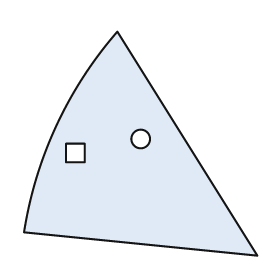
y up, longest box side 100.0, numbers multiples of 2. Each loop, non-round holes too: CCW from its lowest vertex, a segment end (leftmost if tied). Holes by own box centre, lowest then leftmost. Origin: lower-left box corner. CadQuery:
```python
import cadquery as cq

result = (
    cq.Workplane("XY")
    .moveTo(100.0, 0.0)
    .lineTo(40.0, 96.0)
    .threePointArc((14.0, 56.0), (0.0, 10.0))
    .close()
    .moveTo(18.0, 40.0)
    .lineTo(26.0, 40.0)
    .lineTo(26.0, 48.0)
    .lineTo(18.0, 48.0)
    .close()
    .moveTo(50.0, 50.0)
    .circle(4.0)
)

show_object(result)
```